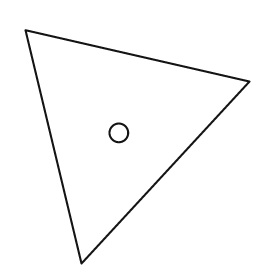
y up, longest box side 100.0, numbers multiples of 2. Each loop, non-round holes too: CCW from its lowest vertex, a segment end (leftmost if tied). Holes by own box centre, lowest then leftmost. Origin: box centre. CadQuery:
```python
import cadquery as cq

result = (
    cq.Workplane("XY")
    .moveTo(-24.0, -50.0)
    .lineTo(48.0, 28.0)
    .lineTo(-48.0, 50.0)
    .close()
    .moveTo(-8.0, 6.0)
    .circle(4.0)
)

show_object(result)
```